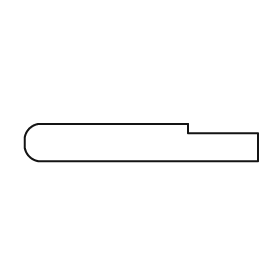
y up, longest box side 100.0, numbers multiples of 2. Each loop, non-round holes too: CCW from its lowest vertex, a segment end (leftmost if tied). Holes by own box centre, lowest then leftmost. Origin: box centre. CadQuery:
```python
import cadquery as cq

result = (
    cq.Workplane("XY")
    .moveTo(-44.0, -8.0)
    .lineTo(50.0, -8.0)
    .lineTo(50.0, 4.0)
    .lineTo(20.0, 4.0)
    .lineTo(20.0, 8.0)
    .lineTo(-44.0, 8.0)
    .threePointArc((-48.0, 6.0), (-50.0, 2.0))
    .lineTo(-50.0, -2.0)
    .threePointArc((-48.0, -6.0), (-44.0, -8.0))
    .close()
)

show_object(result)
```